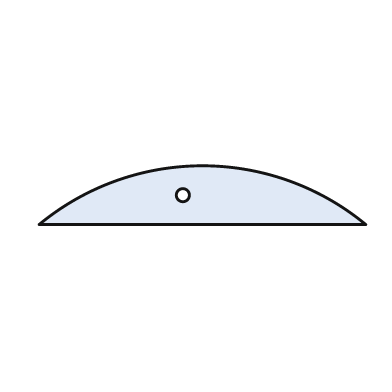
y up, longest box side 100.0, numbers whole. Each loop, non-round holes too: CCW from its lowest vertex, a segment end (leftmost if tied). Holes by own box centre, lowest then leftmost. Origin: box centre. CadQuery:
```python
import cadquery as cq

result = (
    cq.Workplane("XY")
    .moveTo(-50.0, -9.0)
    .lineTo(50.0, -9.0)
    .threePointArc((0.0, 9.0), (-50.0, -9.0))
    .close()
    .moveTo(-6.0, 0.0)
    .circle(2.0)
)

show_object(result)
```